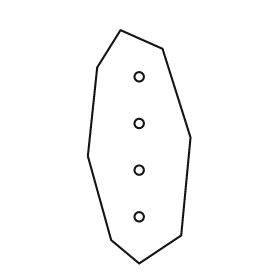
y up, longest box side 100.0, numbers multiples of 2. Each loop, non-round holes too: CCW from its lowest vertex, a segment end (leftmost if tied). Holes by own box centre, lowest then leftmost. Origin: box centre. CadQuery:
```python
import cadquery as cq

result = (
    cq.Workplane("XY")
    .moveTo(0.0, -50.0)
    .lineTo(18.0, -38.0)
    .lineTo(22.0, 4.0)
    .lineTo(10.0, 42.0)
    .lineTo(-8.0, 50.0)
    .lineTo(-18.0, 34.0)
    .lineTo(-22.0, -4.0)
    .lineTo(-12.0, -40.0)
    .close()
    .moveTo(0.0, -30.0)
    .circle(2.0)
    .moveTo(0.0, -10.0)
    .circle(2.0)
    .moveTo(0.0, 10.0)
    .circle(2.0)
    .moveTo(0.0, 30.0)
    .circle(2.0)
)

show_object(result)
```